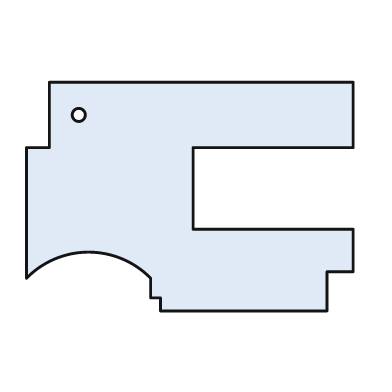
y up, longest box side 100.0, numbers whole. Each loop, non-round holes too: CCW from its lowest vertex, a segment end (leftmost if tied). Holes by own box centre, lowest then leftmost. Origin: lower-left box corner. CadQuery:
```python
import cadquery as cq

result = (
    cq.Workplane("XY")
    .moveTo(41.0, 0.0)
    .lineTo(92.0, 0.0)
    .lineTo(92.0, 12.0)
    .lineTo(100.0, 12.0)
    .lineTo(100.0, 25.0)
    .lineTo(51.0, 25.0)
    .lineTo(51.0, 50.0)
    .lineTo(100.0, 50.0)
    .lineTo(100.0, 70.0)
    .lineTo(7.0, 70.0)
    .lineTo(7.0, 50.0)
    .lineTo(0.0, 50.0)
    .lineTo(0.0, 10.0)
    .threePointArc((19.0, 18.0), (38.0, 10.0))
    .lineTo(38.0, 4.0)
    .lineTo(41.0, 4.0)
    .close()
    .moveTo(16.0, 60.0)
    .circle(2.0)
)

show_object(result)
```